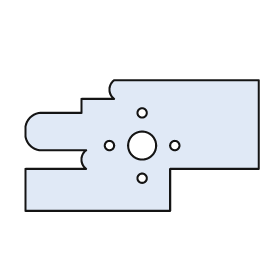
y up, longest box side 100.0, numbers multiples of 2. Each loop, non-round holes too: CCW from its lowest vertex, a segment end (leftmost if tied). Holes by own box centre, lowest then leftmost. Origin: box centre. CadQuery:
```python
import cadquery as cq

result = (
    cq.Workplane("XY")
    .moveTo(-50.0, -28.0)
    .lineTo(12.0, -28.0)
    .lineTo(12.0, -10.0)
    .lineTo(50.0, -10.0)
    .lineTo(50.0, 28.0)
    .lineTo(-12.0, 28.0)
    .threePointArc((-14.0, 24.0), (-12.0, 20.0))
    .lineTo(-26.0, 20.0)
    .lineTo(-26.0, 14.0)
    .lineTo(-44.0, 14.0)
    .threePointArc((-48.0, 12.0), (-50.0, 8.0))
    .lineTo(-50.0, 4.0)
    .threePointArc((-48.0, 0.0), (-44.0, -2.0))
    .lineTo(-24.0, -2.0)
    .threePointArc((-26.0, -6.0), (-24.0, -10.0))
    .lineTo(-50.0, -10.0)
    .close()
    .moveTo(0.0, -14.0)
    .circle(2.0)
    .moveTo(-14.0, 0.0)
    .circle(2.0)
    .moveTo(0.0, 0.0)
    .circle(6.0)
    .moveTo(14.0, 0.0)
    .circle(2.0)
    .moveTo(0.0, 14.0)
    .circle(2.0)
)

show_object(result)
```